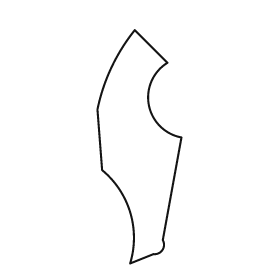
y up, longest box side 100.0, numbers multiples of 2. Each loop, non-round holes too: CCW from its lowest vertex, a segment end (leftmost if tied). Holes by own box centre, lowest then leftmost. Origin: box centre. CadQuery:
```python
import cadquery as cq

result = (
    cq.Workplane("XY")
    .moveTo(-4.0, -50.0)
    .lineTo(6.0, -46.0)
    .threePointArc((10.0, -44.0), (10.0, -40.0))
    .lineTo(18.0, 4.0)
    .threePointArc((4.0, 18.0), (12.0, 36.0))
    .lineTo(-2.0, 50.0)
    .threePointArc((-12.0, 34.0), (-18.0, 16.0))
    .lineTo(-16.0, -10.0)
    .threePointArc((-4.0, -28.0), (-4.0, -50.0))
    .close()
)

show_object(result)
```